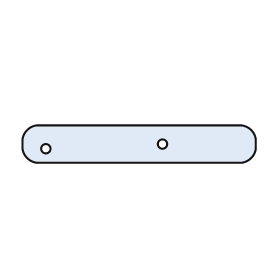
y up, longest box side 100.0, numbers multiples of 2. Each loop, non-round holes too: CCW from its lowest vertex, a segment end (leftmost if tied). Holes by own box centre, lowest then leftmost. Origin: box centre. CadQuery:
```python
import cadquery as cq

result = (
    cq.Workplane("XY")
    .moveTo(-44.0, -8.0)
    .lineTo(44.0, -8.0)
    .threePointArc((48.0, -6.0), (50.0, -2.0))
    .lineTo(50.0, 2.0)
    .threePointArc((48.0, 6.0), (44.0, 8.0))
    .lineTo(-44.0, 8.0)
    .threePointArc((-48.0, 6.0), (-50.0, 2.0))
    .lineTo(-50.0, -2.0)
    .threePointArc((-48.0, -6.0), (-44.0, -8.0))
    .close()
    .moveTo(-40.0, -2.0)
    .circle(2.0)
    .moveTo(10.0, 0.0)
    .circle(2.0)
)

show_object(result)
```